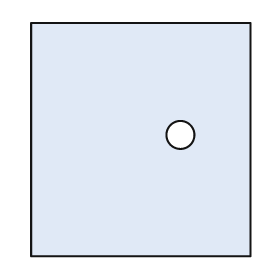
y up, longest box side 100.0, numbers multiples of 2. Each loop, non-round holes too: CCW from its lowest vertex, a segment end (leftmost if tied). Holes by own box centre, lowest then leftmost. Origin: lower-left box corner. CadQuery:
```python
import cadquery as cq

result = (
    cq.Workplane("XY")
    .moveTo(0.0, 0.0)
    .lineTo(94.0, 0.0)
    .lineTo(94.0, 100.0)
    .lineTo(0.0, 100.0)
    .close()
    .moveTo(64.0, 52.0)
    .circle(6.0)
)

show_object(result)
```